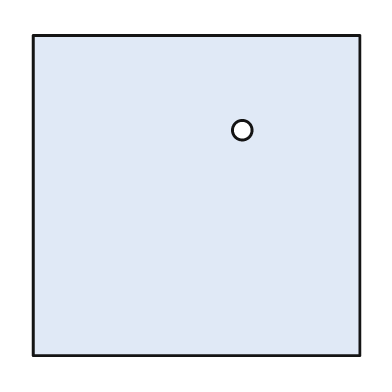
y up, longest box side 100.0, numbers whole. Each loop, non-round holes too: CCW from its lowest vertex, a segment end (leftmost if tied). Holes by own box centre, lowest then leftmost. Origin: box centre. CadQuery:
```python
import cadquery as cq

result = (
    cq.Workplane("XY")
    .moveTo(-50.0, -49.0)
    .lineTo(50.0, -49.0)
    .lineTo(50.0, 49.0)
    .lineTo(-50.0, 49.0)
    .close()
    .moveTo(14.0, 20.0)
    .circle(3.0)
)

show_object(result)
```